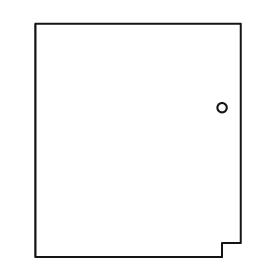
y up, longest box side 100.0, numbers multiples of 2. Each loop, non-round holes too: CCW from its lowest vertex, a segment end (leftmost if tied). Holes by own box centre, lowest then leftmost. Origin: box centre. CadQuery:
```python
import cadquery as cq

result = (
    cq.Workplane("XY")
    .moveTo(-44.0, -50.0)
    .lineTo(36.0, -50.0)
    .lineTo(36.0, -44.0)
    .lineTo(44.0, -44.0)
    .lineTo(44.0, 50.0)
    .lineTo(-44.0, 50.0)
    .close()
    .moveTo(36.0, 14.0)
    .circle(2.0)
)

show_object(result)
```